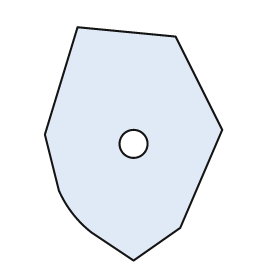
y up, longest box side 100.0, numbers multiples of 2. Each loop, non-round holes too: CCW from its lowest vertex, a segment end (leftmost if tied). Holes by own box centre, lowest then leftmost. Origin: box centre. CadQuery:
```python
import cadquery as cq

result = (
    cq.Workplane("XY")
    .moveTo(0.0, -50.0)
    .lineTo(20.0, -36.0)
    .lineTo(38.0, 6.0)
    .lineTo(18.0, 46.0)
    .lineTo(-24.0, 50.0)
    .lineTo(-38.0, 4.0)
    .lineTo(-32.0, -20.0)
    .threePointArc((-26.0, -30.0), (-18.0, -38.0))
    .close()
    .moveTo(0.0, 0.0)
    .circle(6.0)
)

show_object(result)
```